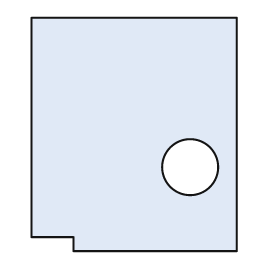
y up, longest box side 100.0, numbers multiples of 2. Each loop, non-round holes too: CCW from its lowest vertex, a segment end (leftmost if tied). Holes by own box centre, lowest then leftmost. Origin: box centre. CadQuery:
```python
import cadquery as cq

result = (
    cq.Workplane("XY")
    .moveTo(-26.0, -50.0)
    .lineTo(44.0, -50.0)
    .lineTo(44.0, 50.0)
    .lineTo(-44.0, 50.0)
    .lineTo(-44.0, -44.0)
    .lineTo(-26.0, -44.0)
    .close()
    .moveTo(24.0, -14.0)
    .circle(12.0)
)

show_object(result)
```